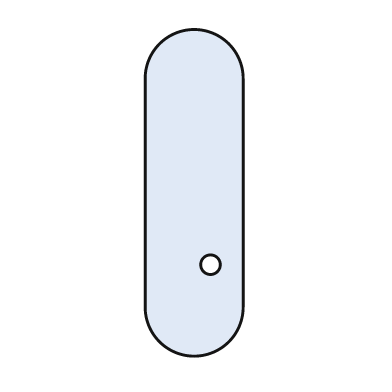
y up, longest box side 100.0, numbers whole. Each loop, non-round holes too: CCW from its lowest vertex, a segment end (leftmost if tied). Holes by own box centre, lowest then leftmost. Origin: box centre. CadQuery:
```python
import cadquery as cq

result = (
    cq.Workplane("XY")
    .moveTo(-15.0, -35.0)
    .threePointArc((0.0, -50.0), (15.0, -35.0))
    .lineTo(15.0, 35.0)
    .threePointArc((0.0, 50.0), (-15.0, 35.0))
    .close()
    .moveTo(5.0, -22.0)
    .circle(3.0)
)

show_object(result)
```